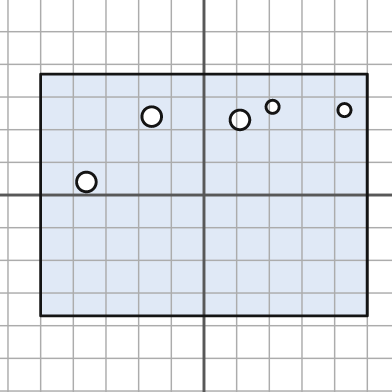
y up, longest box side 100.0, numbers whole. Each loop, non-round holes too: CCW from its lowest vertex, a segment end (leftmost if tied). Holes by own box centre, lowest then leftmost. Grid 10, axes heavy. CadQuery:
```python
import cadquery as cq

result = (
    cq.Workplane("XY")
    .moveTo(-50.0, -37.0)
    .lineTo(50.0, -37.0)
    .lineTo(50.0, 37.0)
    .lineTo(-50.0, 37.0)
    .close()
    .moveTo(-36.0, 4.0)
    .circle(3.0)
    .moveTo(11.0, 23.0)
    .circle(3.0)
    .moveTo(-16.0, 24.0)
    .circle(3.0)
    .moveTo(43.0, 26.0)
    .circle(2.0)
    .moveTo(21.0, 27.0)
    .circle(2.0)
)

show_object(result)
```